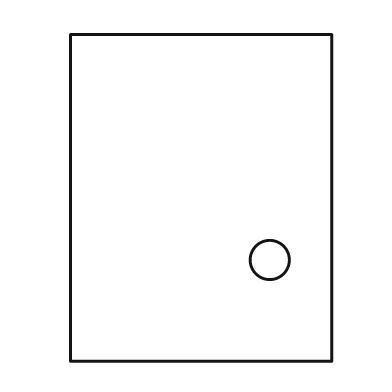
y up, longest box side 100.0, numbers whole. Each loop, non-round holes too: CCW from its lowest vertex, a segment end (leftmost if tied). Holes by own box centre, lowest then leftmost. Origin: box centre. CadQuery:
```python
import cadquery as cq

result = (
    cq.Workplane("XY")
    .moveTo(-40.0, -50.0)
    .lineTo(40.0, -50.0)
    .lineTo(40.0, 50.0)
    .lineTo(-40.0, 50.0)
    .close()
    .moveTo(21.0, -19.0)
    .circle(6.0)
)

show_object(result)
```